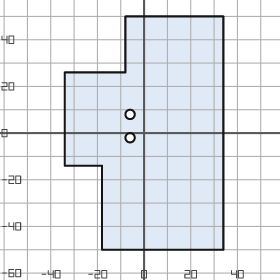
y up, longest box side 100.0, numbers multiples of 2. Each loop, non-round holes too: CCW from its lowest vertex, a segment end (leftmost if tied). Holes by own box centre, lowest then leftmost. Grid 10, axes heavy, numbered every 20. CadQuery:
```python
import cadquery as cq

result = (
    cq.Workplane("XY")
    .moveTo(-18.0, -50.0)
    .lineTo(34.0, -50.0)
    .lineTo(34.0, 50.0)
    .lineTo(-8.0, 50.0)
    .lineTo(-8.0, 26.0)
    .lineTo(-34.0, 26.0)
    .lineTo(-34.0, -14.0)
    .lineTo(-18.0, -14.0)
    .close()
    .moveTo(-6.0, -2.0)
    .circle(2.0)
    .moveTo(-6.0, 8.0)
    .circle(2.0)
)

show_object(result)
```